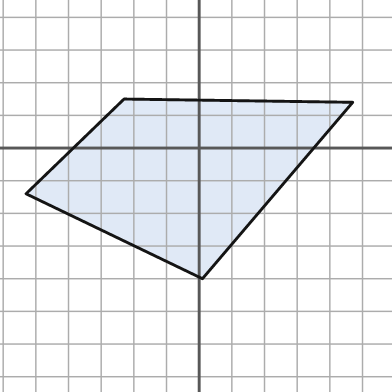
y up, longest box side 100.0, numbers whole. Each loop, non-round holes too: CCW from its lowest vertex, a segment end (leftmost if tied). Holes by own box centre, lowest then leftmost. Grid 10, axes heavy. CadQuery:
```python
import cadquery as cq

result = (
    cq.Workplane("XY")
    .moveTo(1.0, -40.0)
    .lineTo(47.0, 14.0)
    .lineTo(-23.0, 15.0)
    .lineTo(-53.0, -14.0)
    .close()
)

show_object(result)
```